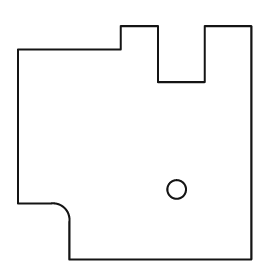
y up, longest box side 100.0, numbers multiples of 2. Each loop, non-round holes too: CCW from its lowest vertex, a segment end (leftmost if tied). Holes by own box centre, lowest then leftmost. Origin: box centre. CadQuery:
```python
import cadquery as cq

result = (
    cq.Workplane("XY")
    .moveTo(-28.0, -50.0)
    .lineTo(50.0, -50.0)
    .lineTo(50.0, 50.0)
    .lineTo(30.0, 50.0)
    .lineTo(30.0, 26.0)
    .lineTo(10.0, 26.0)
    .lineTo(10.0, 50.0)
    .lineTo(-6.0, 50.0)
    .lineTo(-6.0, 40.0)
    .lineTo(-50.0, 40.0)
    .lineTo(-50.0, -26.0)
    .lineTo(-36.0, -26.0)
    .threePointArc((-30.0, -28.0), (-28.0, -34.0))
    .close()
    .moveTo(18.0, -20.0)
    .circle(4.0)
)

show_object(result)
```